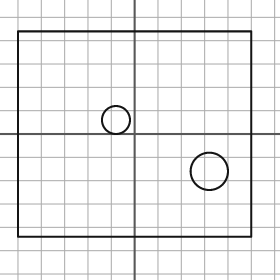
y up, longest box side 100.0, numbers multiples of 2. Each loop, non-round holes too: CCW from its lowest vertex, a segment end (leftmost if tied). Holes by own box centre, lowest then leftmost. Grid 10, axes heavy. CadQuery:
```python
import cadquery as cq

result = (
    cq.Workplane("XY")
    .moveTo(-50.0, -44.0)
    .lineTo(50.0, -44.0)
    .lineTo(50.0, 44.0)
    .lineTo(-50.0, 44.0)
    .close()
    .moveTo(32.0, -16.0)
    .circle(8.0)
    .moveTo(-8.0, 6.0)
    .circle(6.0)
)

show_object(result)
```